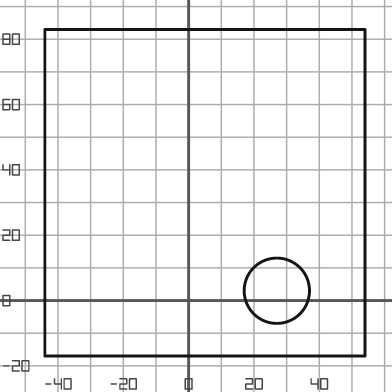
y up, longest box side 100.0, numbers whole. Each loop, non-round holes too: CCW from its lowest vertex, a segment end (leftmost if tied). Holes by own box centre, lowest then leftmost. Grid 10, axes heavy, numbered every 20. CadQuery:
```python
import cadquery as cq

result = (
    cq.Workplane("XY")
    .moveTo(-44.0, -17.0)
    .lineTo(54.0, -17.0)
    .lineTo(54.0, 83.0)
    .lineTo(-44.0, 83.0)
    .close()
    .moveTo(27.0, 3.0)
    .circle(10.0)
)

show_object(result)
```